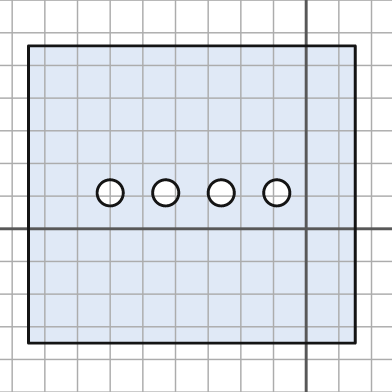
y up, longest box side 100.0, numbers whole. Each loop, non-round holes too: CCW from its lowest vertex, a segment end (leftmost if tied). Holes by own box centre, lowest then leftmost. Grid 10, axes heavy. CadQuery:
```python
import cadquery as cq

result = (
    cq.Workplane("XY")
    .moveTo(-85.0, -35.0)
    .lineTo(15.0, -35.0)
    .lineTo(15.0, 56.0)
    .lineTo(-85.0, 56.0)
    .close()
    .moveTo(-60.0, 11.0)
    .circle(4.0)
    .moveTo(-43.0, 11.0)
    .circle(4.0)
    .moveTo(-26.0, 11.0)
    .circle(4.0)
    .moveTo(-9.0, 11.0)
    .circle(4.0)
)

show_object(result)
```